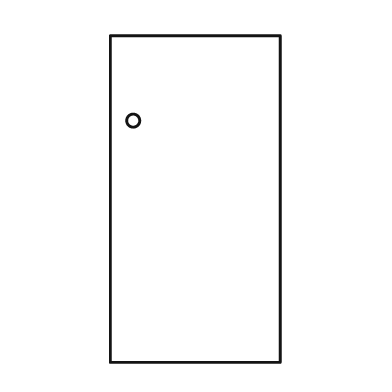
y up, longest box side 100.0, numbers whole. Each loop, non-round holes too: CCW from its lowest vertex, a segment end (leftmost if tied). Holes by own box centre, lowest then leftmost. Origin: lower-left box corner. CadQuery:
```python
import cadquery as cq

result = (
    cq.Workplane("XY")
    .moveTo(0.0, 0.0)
    .lineTo(52.0, 0.0)
    .lineTo(52.0, 100.0)
    .lineTo(0.0, 100.0)
    .close()
    .moveTo(7.0, 74.0)
    .circle(2.0)
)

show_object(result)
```